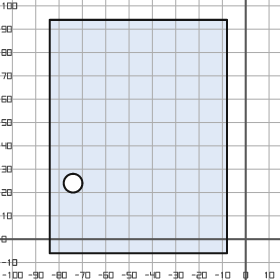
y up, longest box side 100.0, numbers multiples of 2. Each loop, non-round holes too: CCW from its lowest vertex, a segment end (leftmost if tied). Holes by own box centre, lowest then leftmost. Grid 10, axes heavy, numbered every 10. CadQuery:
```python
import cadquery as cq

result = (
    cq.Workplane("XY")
    .moveTo(-84.0, -6.0)
    .lineTo(-8.0, -6.0)
    .lineTo(-8.0, 94.0)
    .lineTo(-84.0, 94.0)
    .close()
    .moveTo(-74.0, 24.0)
    .circle(4.0)
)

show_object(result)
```